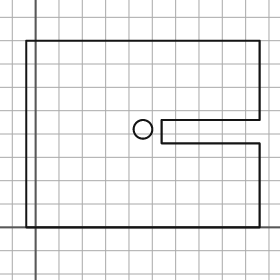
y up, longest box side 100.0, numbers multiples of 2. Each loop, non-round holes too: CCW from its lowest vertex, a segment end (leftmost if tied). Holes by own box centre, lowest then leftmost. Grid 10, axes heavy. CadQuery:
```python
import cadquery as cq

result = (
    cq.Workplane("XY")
    .moveTo(-4.0, 0.0)
    .lineTo(96.0, 0.0)
    .lineTo(96.0, 36.0)
    .lineTo(54.0, 36.0)
    .lineTo(54.0, 46.0)
    .lineTo(96.0, 46.0)
    .lineTo(96.0, 80.0)
    .lineTo(-4.0, 80.0)
    .close()
    .moveTo(46.0, 42.0)
    .circle(4.0)
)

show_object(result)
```